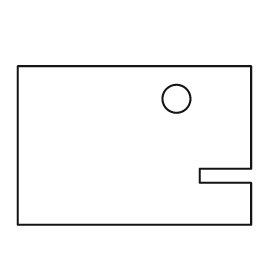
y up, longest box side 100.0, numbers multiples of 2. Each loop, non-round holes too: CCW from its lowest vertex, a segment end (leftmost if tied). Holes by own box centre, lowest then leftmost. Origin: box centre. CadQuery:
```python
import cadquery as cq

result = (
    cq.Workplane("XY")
    .moveTo(-50.0, -34.0)
    .lineTo(50.0, -34.0)
    .lineTo(50.0, -16.0)
    .lineTo(28.0, -16.0)
    .lineTo(28.0, -10.0)
    .lineTo(50.0, -10.0)
    .lineTo(50.0, 34.0)
    .lineTo(-50.0, 34.0)
    .close()
    .moveTo(18.0, 20.0)
    .circle(6.0)
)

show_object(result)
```